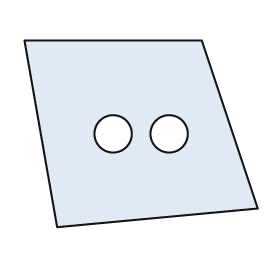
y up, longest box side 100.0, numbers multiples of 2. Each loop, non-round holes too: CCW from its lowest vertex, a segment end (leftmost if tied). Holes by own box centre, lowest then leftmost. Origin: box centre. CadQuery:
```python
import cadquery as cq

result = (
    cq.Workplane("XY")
    .moveTo(-36.0, -40.0)
    .lineTo(50.0, -32.0)
    .lineTo(26.0, 40.0)
    .lineTo(-50.0, 40.0)
    .close()
    .moveTo(-12.0, 0.0)
    .circle(8.0)
    .moveTo(12.0, 0.0)
    .circle(8.0)
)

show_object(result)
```